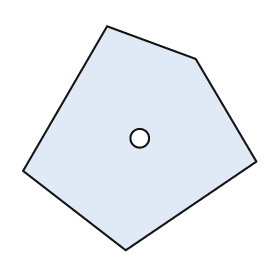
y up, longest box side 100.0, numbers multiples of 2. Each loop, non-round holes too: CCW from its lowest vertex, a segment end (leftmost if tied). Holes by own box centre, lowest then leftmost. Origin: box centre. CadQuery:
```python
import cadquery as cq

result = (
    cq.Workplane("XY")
    .moveTo(-6.0, -48.0)
    .lineTo(50.0, -10.0)
    .lineTo(24.0, 34.0)
    .lineTo(-14.0, 48.0)
    .lineTo(-50.0, -14.0)
    .close()
    .moveTo(0.0, 0.0)
    .circle(4.0)
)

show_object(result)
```